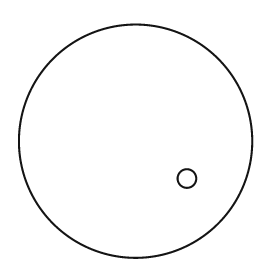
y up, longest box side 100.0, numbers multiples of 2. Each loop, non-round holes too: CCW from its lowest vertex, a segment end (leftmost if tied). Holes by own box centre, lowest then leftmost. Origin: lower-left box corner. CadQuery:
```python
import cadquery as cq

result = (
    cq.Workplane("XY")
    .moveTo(50.0, 50.0)
    .circle(50.0)
    .moveTo(72.0, 34.0)
    .circle(4.0)
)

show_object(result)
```